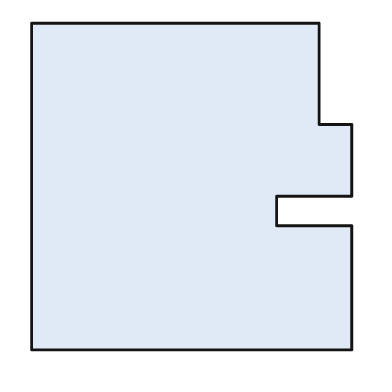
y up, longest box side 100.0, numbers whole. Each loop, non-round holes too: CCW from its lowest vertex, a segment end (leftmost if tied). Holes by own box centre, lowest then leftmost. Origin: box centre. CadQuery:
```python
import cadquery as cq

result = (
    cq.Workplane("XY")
    .moveTo(-49.0, -50.0)
    .lineTo(49.0, -50.0)
    .lineTo(49.0, -12.0)
    .lineTo(26.0, -12.0)
    .lineTo(26.0, -3.0)
    .lineTo(49.0, -3.0)
    .lineTo(49.0, 19.0)
    .lineTo(39.0, 19.0)
    .lineTo(39.0, 50.0)
    .lineTo(-49.0, 50.0)
    .close()
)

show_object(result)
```